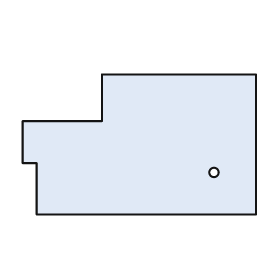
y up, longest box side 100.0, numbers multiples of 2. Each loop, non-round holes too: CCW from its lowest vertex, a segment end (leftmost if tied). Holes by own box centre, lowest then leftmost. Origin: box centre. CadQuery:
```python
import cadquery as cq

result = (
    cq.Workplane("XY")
    .moveTo(-44.0, -30.0)
    .lineTo(50.0, -30.0)
    .lineTo(50.0, 30.0)
    .lineTo(-16.0, 30.0)
    .lineTo(-16.0, 10.0)
    .lineTo(-50.0, 10.0)
    .lineTo(-50.0, -8.0)
    .lineTo(-44.0, -8.0)
    .close()
    .moveTo(32.0, -12.0)
    .circle(2.0)
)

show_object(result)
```